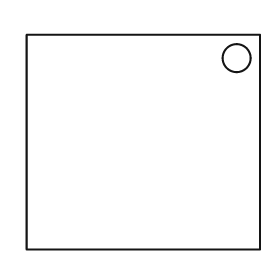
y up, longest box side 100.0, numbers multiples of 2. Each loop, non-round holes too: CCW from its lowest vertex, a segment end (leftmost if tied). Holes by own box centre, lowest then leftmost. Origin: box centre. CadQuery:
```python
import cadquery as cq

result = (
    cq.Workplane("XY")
    .moveTo(-50.0, -46.0)
    .lineTo(50.0, -46.0)
    .lineTo(50.0, 46.0)
    .lineTo(-50.0, 46.0)
    .close()
    .moveTo(40.0, 36.0)
    .circle(6.0)
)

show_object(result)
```